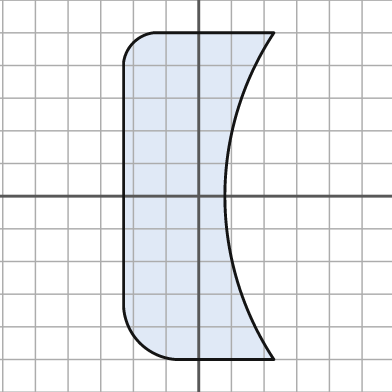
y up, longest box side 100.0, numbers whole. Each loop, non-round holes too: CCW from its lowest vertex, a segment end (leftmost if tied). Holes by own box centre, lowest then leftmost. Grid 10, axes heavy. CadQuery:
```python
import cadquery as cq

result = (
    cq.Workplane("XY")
    .moveTo(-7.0, -50.0)
    .lineTo(23.0, -50.0)
    .threePointArc((8.0, 0.0), (23.0, 50.0))
    .lineTo(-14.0, 50.0)
    .threePointArc((-20.0, 47.0), (-23.0, 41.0))
    .lineTo(-23.0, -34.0)
    .threePointArc((-18.0, -45.0), (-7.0, -50.0))
    .close()
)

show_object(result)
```